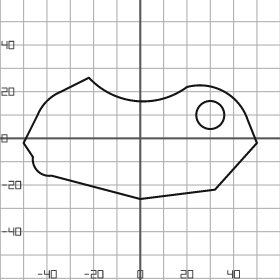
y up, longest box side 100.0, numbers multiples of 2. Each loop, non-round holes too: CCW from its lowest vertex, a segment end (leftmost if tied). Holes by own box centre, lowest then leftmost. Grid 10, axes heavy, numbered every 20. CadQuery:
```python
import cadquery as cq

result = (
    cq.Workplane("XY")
    .moveTo(0.0, -26.0)
    .lineTo(32.0, -22.0)
    .lineTo(50.0, -2.0)
    .lineTo(46.0, 8.0)
    .threePointArc((36.0, 20.0), (20.0, 22.0))
    .threePointArc((-2.0, 16.0), (-22.0, 26.0))
    .lineTo(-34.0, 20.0)
    .threePointArc((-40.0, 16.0), (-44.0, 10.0))
    .lineTo(-50.0, -2.0)
    .lineTo(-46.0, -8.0)
    .threePointArc((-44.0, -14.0), (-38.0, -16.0))
    .close()
    .moveTo(30.0, 10.0)
    .circle(6.0)
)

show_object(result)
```